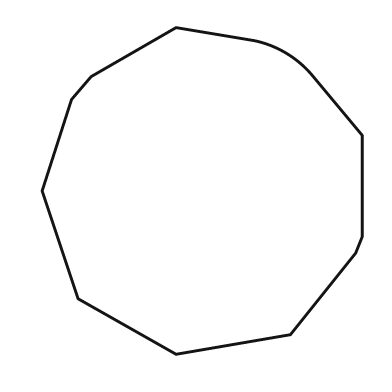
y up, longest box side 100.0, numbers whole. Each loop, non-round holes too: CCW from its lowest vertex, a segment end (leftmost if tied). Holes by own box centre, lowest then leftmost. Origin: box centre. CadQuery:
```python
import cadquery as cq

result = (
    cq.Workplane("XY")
    .moveTo(-8.0, -50.0)
    .lineTo(27.0, -44.0)
    .lineTo(47.0, -19.0)
    .lineTo(49.0, -14.0)
    .lineTo(49.0, 17.0)
    .lineTo(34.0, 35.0)
    .threePointArc((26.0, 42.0), (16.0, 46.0))
    .lineTo(-8.0, 50.0)
    .lineTo(-34.0, 35.0)
    .lineTo(-40.0, 28.0)
    .lineTo(-49.0, 0.0)
    .lineTo(-38.0, -33.0)
    .close()
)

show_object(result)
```